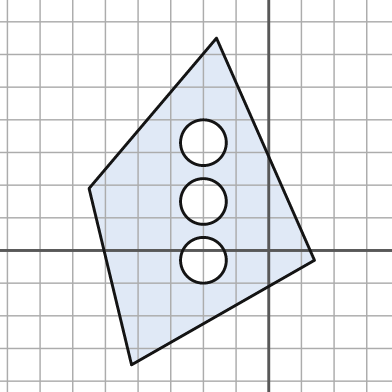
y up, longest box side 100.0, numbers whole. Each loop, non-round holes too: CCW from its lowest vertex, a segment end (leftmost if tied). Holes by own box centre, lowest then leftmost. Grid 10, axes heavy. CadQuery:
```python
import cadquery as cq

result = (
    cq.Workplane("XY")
    .moveTo(-42.0, -35.0)
    .lineTo(14.0, -3.0)
    .lineTo(-16.0, 65.0)
    .lineTo(-55.0, 19.0)
    .close()
    .moveTo(-20.0, -3.0)
    .circle(7.0)
    .moveTo(-20.0, 15.0)
    .circle(7.0)
    .moveTo(-20.0, 33.0)
    .circle(7.0)
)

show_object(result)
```